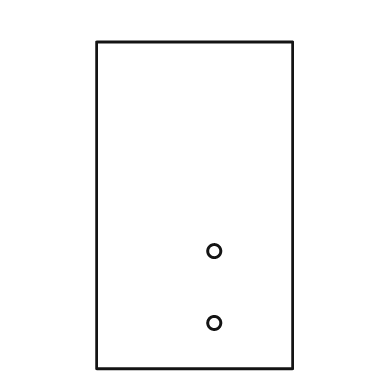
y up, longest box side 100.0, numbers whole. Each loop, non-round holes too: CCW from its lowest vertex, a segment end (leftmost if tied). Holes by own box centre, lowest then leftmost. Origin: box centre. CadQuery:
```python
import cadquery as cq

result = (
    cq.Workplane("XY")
    .moveTo(-30.0, -50.0)
    .lineTo(30.0, -50.0)
    .lineTo(30.0, 50.0)
    .lineTo(-30.0, 50.0)
    .close()
    .moveTo(6.0, -36.0)
    .circle(2.0)
    .moveTo(6.0, -14.0)
    .circle(2.0)
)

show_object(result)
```